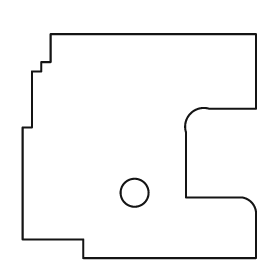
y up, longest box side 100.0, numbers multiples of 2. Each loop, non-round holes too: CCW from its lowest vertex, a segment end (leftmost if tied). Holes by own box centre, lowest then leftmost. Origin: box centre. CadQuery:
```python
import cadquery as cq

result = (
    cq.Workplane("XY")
    .moveTo(-24.0, -48.0)
    .lineTo(50.0, -48.0)
    .lineTo(50.0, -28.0)
    .threePointArc((48.0, -24.0), (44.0, -22.0))
    .lineTo(20.0, -22.0)
    .lineTo(20.0, 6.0)
    .threePointArc((22.0, 14.0), (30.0, 16.0))
    .lineTo(50.0, 16.0)
    .lineTo(50.0, 48.0)
    .lineTo(-38.0, 48.0)
    .lineTo(-38.0, 36.0)
    .lineTo(-42.0, 36.0)
    .lineTo(-42.0, 32.0)
    .lineTo(-46.0, 32.0)
    .lineTo(-46.0, 8.0)
    .lineTo(-50.0, 8.0)
    .lineTo(-50.0, -40.0)
    .lineTo(-24.0, -40.0)
    .close()
    .moveTo(-2.0, -20.0)
    .circle(6.0)
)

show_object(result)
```